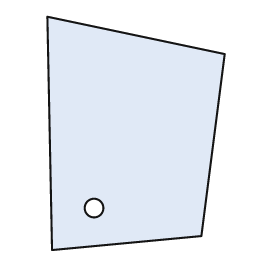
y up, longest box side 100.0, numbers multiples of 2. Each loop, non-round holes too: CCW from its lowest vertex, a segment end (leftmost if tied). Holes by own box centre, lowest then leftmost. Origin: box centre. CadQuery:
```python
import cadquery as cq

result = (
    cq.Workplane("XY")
    .moveTo(-36.0, -50.0)
    .lineTo(28.0, -44.0)
    .lineTo(38.0, 34.0)
    .lineTo(-38.0, 50.0)
    .close()
    .moveTo(-18.0, -32.0)
    .circle(4.0)
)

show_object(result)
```